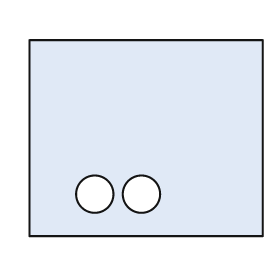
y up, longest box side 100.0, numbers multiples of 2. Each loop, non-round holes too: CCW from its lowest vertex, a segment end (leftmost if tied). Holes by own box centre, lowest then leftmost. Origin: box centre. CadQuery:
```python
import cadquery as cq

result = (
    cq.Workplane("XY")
    .moveTo(-50.0, -42.0)
    .lineTo(50.0, -42.0)
    .lineTo(50.0, 42.0)
    .lineTo(-50.0, 42.0)
    .close()
    .moveTo(-22.0, -24.0)
    .circle(8.0)
    .moveTo(-2.0, -24.0)
    .circle(8.0)
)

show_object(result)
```